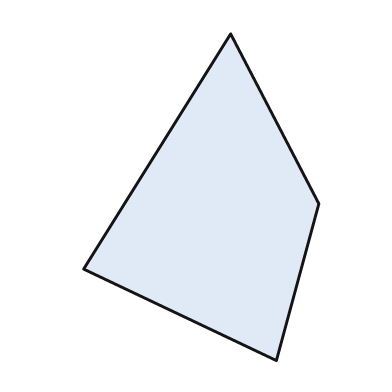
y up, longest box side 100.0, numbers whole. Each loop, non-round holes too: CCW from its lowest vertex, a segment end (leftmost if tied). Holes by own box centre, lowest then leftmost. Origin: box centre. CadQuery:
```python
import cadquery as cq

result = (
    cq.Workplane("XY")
    .moveTo(23.0, -50.0)
    .lineTo(36.0, -2.0)
    .lineTo(9.0, 50.0)
    .lineTo(-36.0, -22.0)
    .close()
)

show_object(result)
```